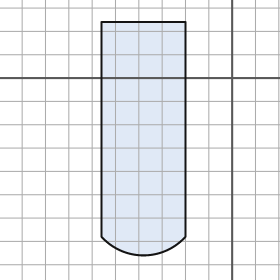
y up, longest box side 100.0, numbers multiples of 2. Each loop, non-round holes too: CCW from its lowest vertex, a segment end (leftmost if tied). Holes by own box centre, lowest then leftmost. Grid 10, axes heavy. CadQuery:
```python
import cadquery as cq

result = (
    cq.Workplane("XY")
    .moveTo(-56.0, -68.0)
    .threePointArc((-38.0, -76.0), (-20.0, -68.0))
    .lineTo(-20.0, 24.0)
    .lineTo(-56.0, 24.0)
    .close()
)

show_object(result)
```